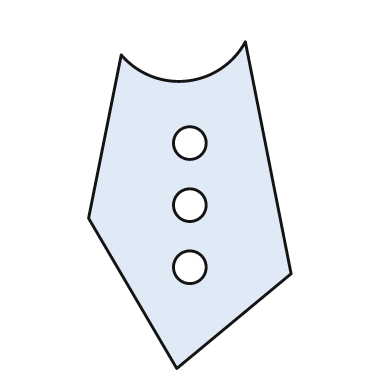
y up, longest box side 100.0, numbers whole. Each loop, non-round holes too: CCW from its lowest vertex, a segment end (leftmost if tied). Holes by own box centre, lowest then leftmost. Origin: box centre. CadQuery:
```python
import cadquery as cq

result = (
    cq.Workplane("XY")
    .moveTo(-4.0, -50.0)
    .lineTo(31.0, -21.0)
    .lineTo(17.0, 50.0)
    .threePointArc((-1.0, 38.0), (-21.0, 46.0))
    .lineTo(-31.0, -4.0)
    .close()
    .moveTo(0.0, -19.0)
    .circle(5.0)
    .moveTo(0.0, 0.0)
    .circle(5.0)
    .moveTo(0.0, 19.0)
    .circle(5.0)
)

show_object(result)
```